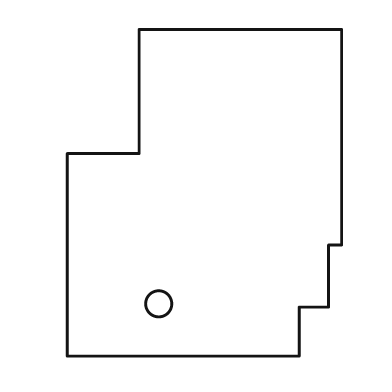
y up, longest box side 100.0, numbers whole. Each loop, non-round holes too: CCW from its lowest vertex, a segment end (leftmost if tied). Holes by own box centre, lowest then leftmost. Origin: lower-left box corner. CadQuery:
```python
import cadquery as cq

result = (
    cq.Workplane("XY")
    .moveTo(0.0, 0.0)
    .lineTo(71.0, 0.0)
    .lineTo(71.0, 15.0)
    .lineTo(80.0, 15.0)
    .lineTo(80.0, 34.0)
    .lineTo(84.0, 34.0)
    .lineTo(84.0, 100.0)
    .lineTo(22.0, 100.0)
    .lineTo(22.0, 62.0)
    .lineTo(0.0, 62.0)
    .close()
    .moveTo(28.0, 16.0)
    .circle(4.0)
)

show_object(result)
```